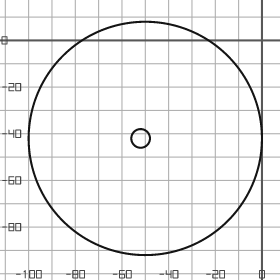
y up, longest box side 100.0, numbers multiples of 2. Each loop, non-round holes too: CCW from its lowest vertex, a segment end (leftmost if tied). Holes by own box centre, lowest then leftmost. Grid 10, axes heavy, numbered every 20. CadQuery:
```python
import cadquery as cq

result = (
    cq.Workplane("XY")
    .moveTo(-50.0, -42.0)
    .circle(50.0)
    .moveTo(-52.0, -42.0)
    .circle(4.0)
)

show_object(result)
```